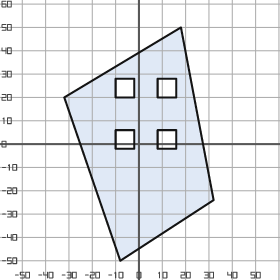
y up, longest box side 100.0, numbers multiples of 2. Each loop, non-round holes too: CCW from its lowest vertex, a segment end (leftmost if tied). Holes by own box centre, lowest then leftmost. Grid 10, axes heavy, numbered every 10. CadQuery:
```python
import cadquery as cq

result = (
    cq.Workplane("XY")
    .moveTo(-8.0, -50.0)
    .lineTo(32.0, -24.0)
    .lineTo(18.0, 50.0)
    .lineTo(-32.0, 20.0)
    .close()
    .moveTo(-10.0, -2.0)
    .lineTo(-2.0, -2.0)
    .lineTo(-2.0, 6.0)
    .lineTo(-10.0, 6.0)
    .close()
    .moveTo(8.0, -2.0)
    .lineTo(16.0, -2.0)
    .lineTo(16.0, 6.0)
    .lineTo(8.0, 6.0)
    .close()
    .moveTo(-10.0, 20.0)
    .lineTo(-2.0, 20.0)
    .lineTo(-2.0, 28.0)
    .lineTo(-10.0, 28.0)
    .close()
    .moveTo(8.0, 20.0)
    .lineTo(16.0, 20.0)
    .lineTo(16.0, 28.0)
    .lineTo(8.0, 28.0)
    .close()
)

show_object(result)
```